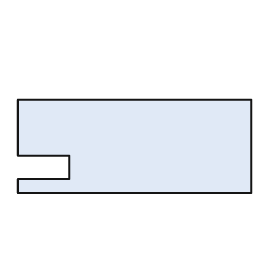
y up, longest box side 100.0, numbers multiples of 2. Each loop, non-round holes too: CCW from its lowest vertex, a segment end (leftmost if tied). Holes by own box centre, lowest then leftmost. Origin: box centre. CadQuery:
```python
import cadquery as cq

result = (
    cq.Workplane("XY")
    .moveTo(-50.0, -20.0)
    .lineTo(50.0, -20.0)
    .lineTo(50.0, 20.0)
    .lineTo(-50.0, 20.0)
    .lineTo(-50.0, -4.0)
    .lineTo(-28.0, -4.0)
    .lineTo(-28.0, -14.0)
    .lineTo(-50.0, -14.0)
    .close()
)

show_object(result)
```